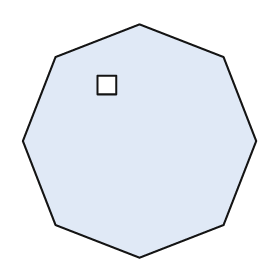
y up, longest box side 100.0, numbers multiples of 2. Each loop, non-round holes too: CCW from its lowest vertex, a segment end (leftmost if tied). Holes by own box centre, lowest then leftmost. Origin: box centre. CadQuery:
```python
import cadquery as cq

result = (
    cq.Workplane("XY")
    .moveTo(0.0, -50.0)
    .lineTo(36.0, -36.0)
    .lineTo(50.0, 0.0)
    .lineTo(36.0, 36.0)
    .lineTo(0.0, 50.0)
    .lineTo(-36.0, 36.0)
    .lineTo(-50.0, 0.0)
    .lineTo(-36.0, -36.0)
    .close()
    .moveTo(-18.0, 20.0)
    .lineTo(-10.0, 20.0)
    .lineTo(-10.0, 28.0)
    .lineTo(-18.0, 28.0)
    .close()
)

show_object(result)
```